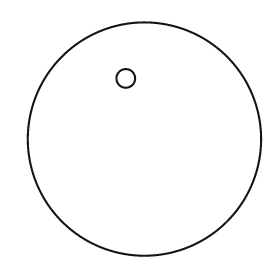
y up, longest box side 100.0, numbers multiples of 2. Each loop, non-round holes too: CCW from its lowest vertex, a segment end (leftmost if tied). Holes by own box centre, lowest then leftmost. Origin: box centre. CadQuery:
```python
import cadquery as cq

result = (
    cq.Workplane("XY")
    .moveTo(0.0, 0.0)
    .circle(50.0)
    .moveTo(-8.0, 26.0)
    .circle(4.0)
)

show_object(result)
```